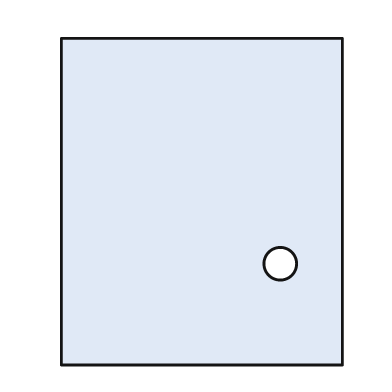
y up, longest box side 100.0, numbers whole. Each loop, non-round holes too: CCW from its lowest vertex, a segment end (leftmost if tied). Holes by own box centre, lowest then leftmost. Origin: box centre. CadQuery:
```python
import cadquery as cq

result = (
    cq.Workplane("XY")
    .moveTo(-43.0, -50.0)
    .lineTo(43.0, -50.0)
    .lineTo(43.0, 50.0)
    .lineTo(-43.0, 50.0)
    .close()
    .moveTo(24.0, -19.0)
    .circle(5.0)
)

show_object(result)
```